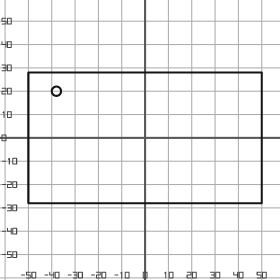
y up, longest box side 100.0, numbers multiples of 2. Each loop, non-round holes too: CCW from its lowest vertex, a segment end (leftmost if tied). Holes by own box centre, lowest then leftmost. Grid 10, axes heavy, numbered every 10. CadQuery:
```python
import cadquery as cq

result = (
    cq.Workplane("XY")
    .moveTo(-50.0, -28.0)
    .lineTo(50.0, -28.0)
    .lineTo(50.0, 28.0)
    .lineTo(-50.0, 28.0)
    .close()
    .moveTo(-38.0, 20.0)
    .circle(2.0)
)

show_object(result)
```